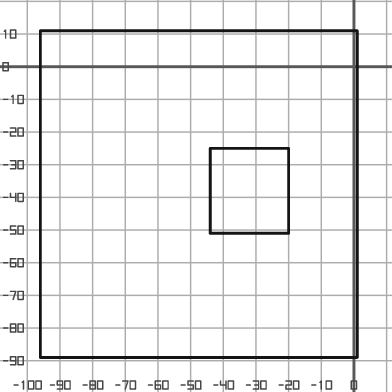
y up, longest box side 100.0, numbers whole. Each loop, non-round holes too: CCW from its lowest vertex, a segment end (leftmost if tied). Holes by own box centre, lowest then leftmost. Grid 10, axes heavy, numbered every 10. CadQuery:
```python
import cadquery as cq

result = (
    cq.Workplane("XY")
    .moveTo(-96.0, -89.0)
    .lineTo(1.0, -89.0)
    .lineTo(1.0, 11.0)
    .lineTo(-96.0, 11.0)
    .close()
    .moveTo(-44.0, -51.0)
    .lineTo(-20.0, -51.0)
    .lineTo(-20.0, -25.0)
    .lineTo(-44.0, -25.0)
    .close()
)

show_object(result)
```